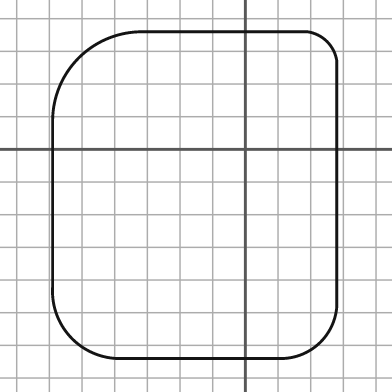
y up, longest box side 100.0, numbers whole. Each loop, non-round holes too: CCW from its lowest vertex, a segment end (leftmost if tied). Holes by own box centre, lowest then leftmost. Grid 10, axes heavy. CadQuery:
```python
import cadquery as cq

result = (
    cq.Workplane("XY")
    .moveTo(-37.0, -64.0)
    .lineTo(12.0, -64.0)
    .threePointArc((23.0, -59.0), (28.0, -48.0))
    .lineTo(28.0, 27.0)
    .threePointArc((25.0, 33.0), (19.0, 36.0))
    .lineTo(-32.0, 36.0)
    .threePointArc((-51.0, 28.0), (-59.0, 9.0))
    .lineTo(-59.0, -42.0)
    .threePointArc((-53.0, -58.0), (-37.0, -64.0))
    .close()
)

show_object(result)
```